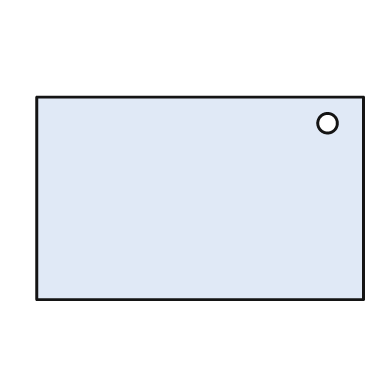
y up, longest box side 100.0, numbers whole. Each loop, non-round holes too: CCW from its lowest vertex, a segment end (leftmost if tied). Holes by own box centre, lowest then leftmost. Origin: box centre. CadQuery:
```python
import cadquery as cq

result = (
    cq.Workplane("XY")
    .moveTo(-50.0, -31.0)
    .lineTo(50.0, -31.0)
    .lineTo(50.0, 31.0)
    .lineTo(-50.0, 31.0)
    .close()
    .moveTo(39.0, 23.0)
    .circle(3.0)
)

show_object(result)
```